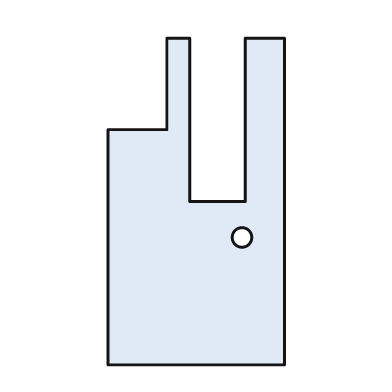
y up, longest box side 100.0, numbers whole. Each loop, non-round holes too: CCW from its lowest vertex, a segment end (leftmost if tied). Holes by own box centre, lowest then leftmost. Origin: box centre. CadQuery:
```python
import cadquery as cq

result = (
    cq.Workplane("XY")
    .moveTo(-27.0, -50.0)
    .lineTo(27.0, -50.0)
    .lineTo(27.0, 50.0)
    .lineTo(15.0, 50.0)
    .lineTo(15.0, 0.0)
    .lineTo(-2.0, 0.0)
    .lineTo(-2.0, 50.0)
    .lineTo(-9.0, 50.0)
    .lineTo(-9.0, 22.0)
    .lineTo(-27.0, 22.0)
    .close()
    .moveTo(14.0, -11.0)
    .circle(3.0)
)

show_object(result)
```